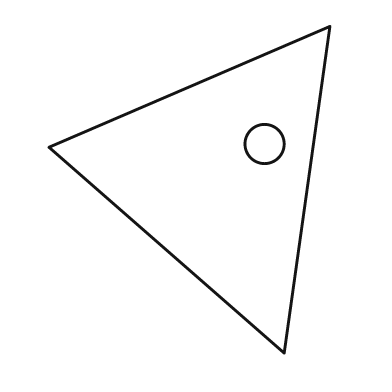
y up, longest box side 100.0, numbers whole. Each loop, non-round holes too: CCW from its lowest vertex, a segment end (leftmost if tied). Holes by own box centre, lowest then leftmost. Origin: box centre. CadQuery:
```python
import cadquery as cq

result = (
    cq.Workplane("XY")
    .moveTo(29.0, -50.0)
    .lineTo(43.0, 50.0)
    .lineTo(-43.0, 13.0)
    .close()
    .moveTo(23.0, 14.0)
    .circle(6.0)
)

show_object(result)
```